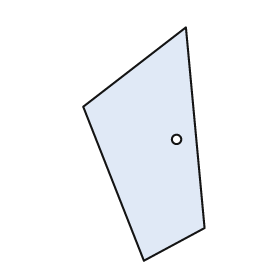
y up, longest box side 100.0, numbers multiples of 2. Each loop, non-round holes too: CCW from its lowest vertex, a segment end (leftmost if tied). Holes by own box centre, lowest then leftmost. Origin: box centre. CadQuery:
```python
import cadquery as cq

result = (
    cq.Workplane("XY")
    .moveTo(0.0, -50.0)
    .lineTo(26.0, -36.0)
    .lineTo(18.0, 50.0)
    .lineTo(-26.0, 16.0)
    .close()
    .moveTo(14.0, 2.0)
    .circle(2.0)
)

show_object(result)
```